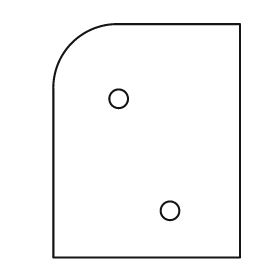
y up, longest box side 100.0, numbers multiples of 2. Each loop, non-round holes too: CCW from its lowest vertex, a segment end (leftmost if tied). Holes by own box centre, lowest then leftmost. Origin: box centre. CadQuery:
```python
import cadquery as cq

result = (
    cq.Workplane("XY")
    .moveTo(-40.0, -50.0)
    .lineTo(40.0, -50.0)
    .lineTo(40.0, 50.0)
    .lineTo(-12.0, 50.0)
    .threePointArc((-32.0, 42.0), (-40.0, 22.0))
    .close()
    .moveTo(10.0, -30.0)
    .circle(4.0)
    .moveTo(-12.0, 18.0)
    .circle(4.0)
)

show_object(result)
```